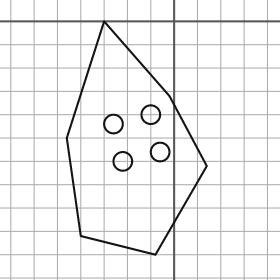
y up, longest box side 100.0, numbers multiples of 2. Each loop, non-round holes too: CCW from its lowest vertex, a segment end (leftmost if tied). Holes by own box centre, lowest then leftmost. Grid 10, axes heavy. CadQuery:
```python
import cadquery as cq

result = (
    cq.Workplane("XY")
    .moveTo(-8.0, -100.0)
    .lineTo(14.0, -62.0)
    .lineTo(-2.0, -32.0)
    .lineTo(-30.0, 0.0)
    .lineTo(-46.0, -50.0)
    .lineTo(-40.0, -92.0)
    .close()
    .moveTo(-22.0, -60.0)
    .circle(4.0)
    .moveTo(-6.0, -56.0)
    .circle(4.0)
    .moveTo(-26.0, -44.0)
    .circle(4.0)
    .moveTo(-10.0, -40.0)
    .circle(4.0)
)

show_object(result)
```